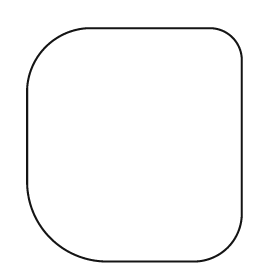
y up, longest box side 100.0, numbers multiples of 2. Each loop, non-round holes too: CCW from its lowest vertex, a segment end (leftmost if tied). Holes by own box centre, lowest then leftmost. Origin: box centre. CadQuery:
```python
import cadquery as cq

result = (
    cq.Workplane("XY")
    .moveTo(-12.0, -50.0)
    .lineTo(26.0, -50.0)
    .threePointArc((40.0, -44.0), (46.0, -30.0))
    .lineTo(46.0, 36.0)
    .threePointArc((42.0, 46.0), (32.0, 50.0))
    .lineTo(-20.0, 50.0)
    .threePointArc((-38.0, 42.0), (-46.0, 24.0))
    .lineTo(-46.0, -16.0)
    .threePointArc((-36.0, -40.0), (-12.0, -50.0))
    .close()
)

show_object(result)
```